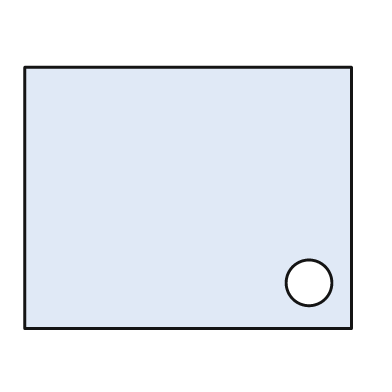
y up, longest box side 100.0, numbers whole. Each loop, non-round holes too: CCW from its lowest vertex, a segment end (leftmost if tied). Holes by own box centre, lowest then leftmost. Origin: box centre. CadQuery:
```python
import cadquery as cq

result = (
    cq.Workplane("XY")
    .moveTo(-50.0, -40.0)
    .lineTo(50.0, -40.0)
    .lineTo(50.0, 40.0)
    .lineTo(-50.0, 40.0)
    .close()
    .moveTo(37.0, -26.0)
    .circle(7.0)
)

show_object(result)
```